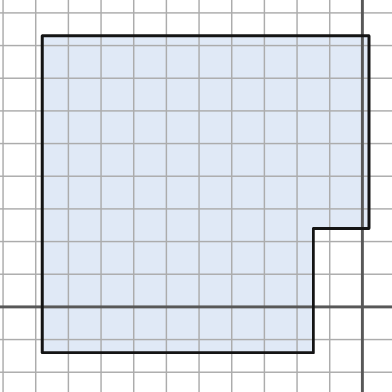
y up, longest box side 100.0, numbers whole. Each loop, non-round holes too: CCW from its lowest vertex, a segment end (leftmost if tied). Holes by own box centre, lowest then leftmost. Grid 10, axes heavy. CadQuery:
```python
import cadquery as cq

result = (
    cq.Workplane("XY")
    .moveTo(-98.0, -14.0)
    .lineTo(-15.0, -14.0)
    .lineTo(-15.0, 24.0)
    .lineTo(2.0, 24.0)
    .lineTo(2.0, 83.0)
    .lineTo(-98.0, 83.0)
    .close()
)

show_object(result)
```